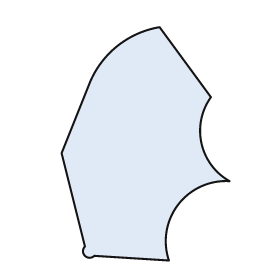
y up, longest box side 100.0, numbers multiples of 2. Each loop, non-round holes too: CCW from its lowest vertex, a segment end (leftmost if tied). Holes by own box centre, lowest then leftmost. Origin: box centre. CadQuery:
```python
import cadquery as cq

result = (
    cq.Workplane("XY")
    .moveTo(10.0, -50.0)
    .threePointArc((14.0, -26.0), (36.0, -16.0))
    .threePointArc((24.0, 0.0), (28.0, 20.0))
    .lineTo(6.0, 50.0)
    .threePointArc((-12.0, 42.0), (-24.0, 26.0))
    .lineTo(-36.0, -4.0)
    .lineTo(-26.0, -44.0)
    .threePointArc((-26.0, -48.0), (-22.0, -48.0))
    .close()
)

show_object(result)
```